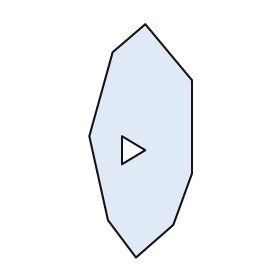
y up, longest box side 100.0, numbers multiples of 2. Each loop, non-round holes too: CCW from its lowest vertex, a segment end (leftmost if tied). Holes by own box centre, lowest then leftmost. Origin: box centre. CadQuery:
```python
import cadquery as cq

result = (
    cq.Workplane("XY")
    .moveTo(-2.0, -50.0)
    .lineTo(14.0, -36.0)
    .lineTo(22.0, -14.0)
    .lineTo(22.0, 26.0)
    .lineTo(2.0, 50.0)
    .lineTo(-12.0, 38.0)
    .lineTo(-22.0, 2.0)
    .lineTo(-14.0, -34.0)
    .close()
    .moveTo(-8.0, -10.0)
    .lineTo(2.0, -4.0)
    .lineTo(-8.0, 2.0)
    .close()
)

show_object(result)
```